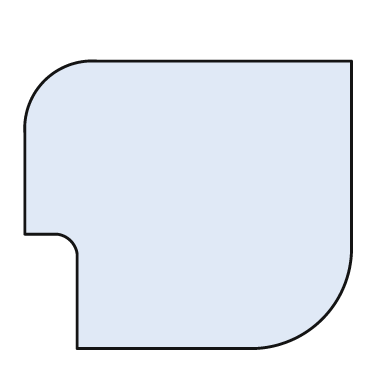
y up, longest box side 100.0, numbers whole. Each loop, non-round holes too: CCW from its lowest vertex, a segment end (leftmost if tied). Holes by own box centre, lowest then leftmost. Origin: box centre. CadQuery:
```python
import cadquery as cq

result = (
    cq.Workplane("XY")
    .moveTo(-34.0, -44.0)
    .lineTo(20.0, -44.0)
    .threePointArc((41.0, -35.0), (50.0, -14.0))
    .lineTo(50.0, 44.0)
    .lineTo(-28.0, 44.0)
    .threePointArc((-44.0, 38.0), (-50.0, 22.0))
    .lineTo(-50.0, -9.0)
    .lineTo(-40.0, -9.0)
    .threePointArc((-36.0, -11.0), (-34.0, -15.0))
    .close()
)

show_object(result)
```